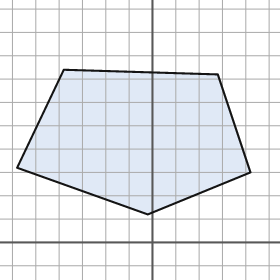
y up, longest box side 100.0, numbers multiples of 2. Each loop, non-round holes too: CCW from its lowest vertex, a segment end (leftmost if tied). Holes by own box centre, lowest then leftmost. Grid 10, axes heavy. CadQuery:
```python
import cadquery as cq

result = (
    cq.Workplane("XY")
    .moveTo(-2.0, 12.0)
    .lineTo(42.0, 30.0)
    .lineTo(28.0, 72.0)
    .lineTo(-38.0, 74.0)
    .lineTo(-58.0, 32.0)
    .close()
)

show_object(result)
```